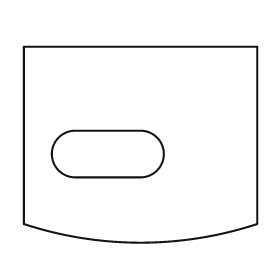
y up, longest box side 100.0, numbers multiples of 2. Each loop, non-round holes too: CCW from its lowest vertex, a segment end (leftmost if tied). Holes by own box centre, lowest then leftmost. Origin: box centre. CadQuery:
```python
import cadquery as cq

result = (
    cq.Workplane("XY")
    .moveTo(-50.0, -34.0)
    .threePointArc((0.0, -42.0), (50.0, -34.0))
    .lineTo(50.0, 42.0)
    .lineTo(-50.0, 42.0)
    .close()
    .moveTo(-28.0, -14.0)
    .lineTo(0.0, -14.0)
    .threePointArc((10.0, -4.0), (0.0, 6.0))
    .lineTo(-28.0, 6.0)
    .threePointArc((-38.0, -4.0), (-28.0, -14.0))
    .close()
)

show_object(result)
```